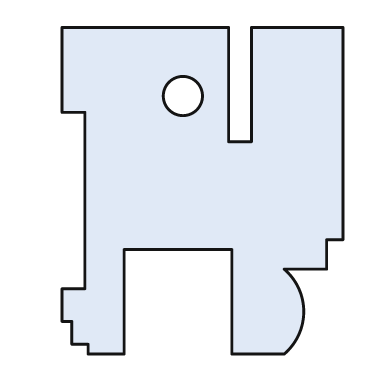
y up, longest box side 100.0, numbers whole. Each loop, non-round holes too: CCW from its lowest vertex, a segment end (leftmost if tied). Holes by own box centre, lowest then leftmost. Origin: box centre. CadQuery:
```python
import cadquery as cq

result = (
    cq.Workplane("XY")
    .moveTo(-35.0, -50.0)
    .lineTo(-24.0, -50.0)
    .lineTo(-24.0, -18.0)
    .lineTo(9.0, -18.0)
    .lineTo(9.0, -50.0)
    .lineTo(25.0, -50.0)
    .threePointArc((31.0, -37.0), (25.0, -24.0))
    .lineTo(38.0, -24.0)
    .lineTo(38.0, -15.0)
    .lineTo(43.0, -15.0)
    .lineTo(43.0, 50.0)
    .lineTo(15.0, 50.0)
    .lineTo(15.0, 15.0)
    .lineTo(8.0, 15.0)
    .lineTo(8.0, 50.0)
    .lineTo(-43.0, 50.0)
    .lineTo(-43.0, 24.0)
    .lineTo(-36.0, 24.0)
    .lineTo(-36.0, -30.0)
    .lineTo(-43.0, -30.0)
    .lineTo(-43.0, -40.0)
    .lineTo(-40.0, -40.0)
    .lineTo(-40.0, -47.0)
    .lineTo(-35.0, -47.0)
    .close()
    .moveTo(-6.0, 29.0)
    .circle(6.0)
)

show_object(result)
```